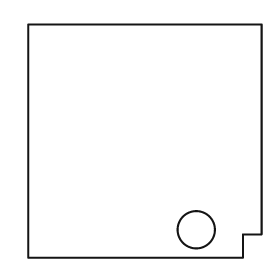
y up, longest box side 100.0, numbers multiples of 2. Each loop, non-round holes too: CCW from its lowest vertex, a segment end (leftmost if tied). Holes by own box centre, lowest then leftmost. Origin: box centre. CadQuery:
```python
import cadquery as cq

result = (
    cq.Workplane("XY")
    .moveTo(-50.0, -50.0)
    .lineTo(42.0, -50.0)
    .lineTo(42.0, -40.0)
    .lineTo(50.0, -40.0)
    .lineTo(50.0, 50.0)
    .lineTo(-50.0, 50.0)
    .close()
    .moveTo(22.0, -38.0)
    .circle(8.0)
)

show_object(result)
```